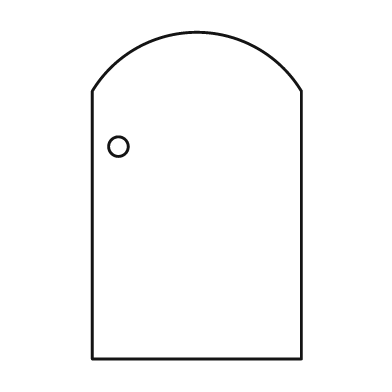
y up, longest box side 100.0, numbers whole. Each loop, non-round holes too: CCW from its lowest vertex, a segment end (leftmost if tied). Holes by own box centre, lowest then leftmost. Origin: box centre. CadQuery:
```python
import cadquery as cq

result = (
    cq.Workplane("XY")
    .moveTo(-32.0, -50.0)
    .lineTo(32.0, -50.0)
    .lineTo(32.0, 32.0)
    .threePointArc((0.0, 50.0), (-32.0, 32.0))
    .close()
    .moveTo(-24.0, 15.0)
    .circle(3.0)
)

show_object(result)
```